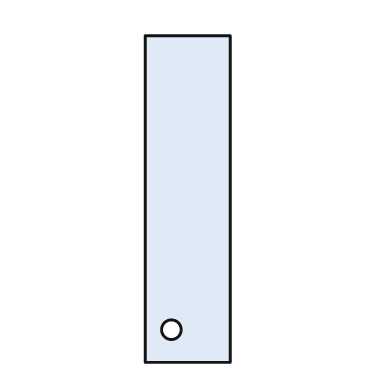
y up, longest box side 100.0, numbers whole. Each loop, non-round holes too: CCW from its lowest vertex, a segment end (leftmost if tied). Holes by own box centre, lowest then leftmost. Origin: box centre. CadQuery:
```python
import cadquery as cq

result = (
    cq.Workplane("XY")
    .moveTo(-13.0, -50.0)
    .lineTo(13.0, -50.0)
    .lineTo(13.0, 50.0)
    .lineTo(-13.0, 50.0)
    .close()
    .moveTo(-5.0, -40.0)
    .circle(3.0)
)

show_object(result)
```